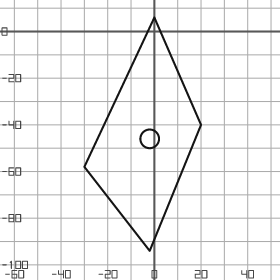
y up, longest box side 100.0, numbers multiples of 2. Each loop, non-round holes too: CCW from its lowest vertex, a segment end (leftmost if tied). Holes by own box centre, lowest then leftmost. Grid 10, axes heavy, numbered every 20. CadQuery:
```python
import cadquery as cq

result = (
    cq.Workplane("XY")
    .moveTo(-2.0, -94.0)
    .lineTo(20.0, -40.0)
    .lineTo(0.0, 6.0)
    .lineTo(-30.0, -58.0)
    .close()
    .moveTo(-2.0, -46.0)
    .circle(4.0)
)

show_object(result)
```